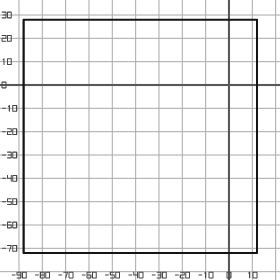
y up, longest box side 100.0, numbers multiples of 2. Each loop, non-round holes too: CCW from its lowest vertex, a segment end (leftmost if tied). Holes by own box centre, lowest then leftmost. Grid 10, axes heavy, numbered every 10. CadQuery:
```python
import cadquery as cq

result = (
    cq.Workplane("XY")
    .moveTo(-88.0, -72.0)
    .lineTo(12.0, -72.0)
    .lineTo(12.0, 28.0)
    .lineTo(-88.0, 28.0)
    .close()
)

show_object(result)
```